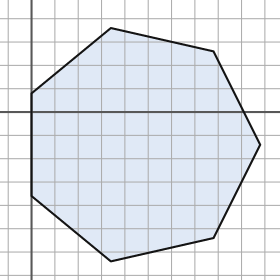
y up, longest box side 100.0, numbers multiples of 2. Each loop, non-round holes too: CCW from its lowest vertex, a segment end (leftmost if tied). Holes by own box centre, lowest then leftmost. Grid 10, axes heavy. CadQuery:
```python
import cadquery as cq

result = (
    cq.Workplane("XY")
    .moveTo(34.0, -64.0)
    .lineTo(78.0, -54.0)
    .lineTo(98.0, -14.0)
    .lineTo(78.0, 26.0)
    .lineTo(34.0, 36.0)
    .lineTo(0.0, 8.0)
    .lineTo(0.0, -36.0)
    .close()
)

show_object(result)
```